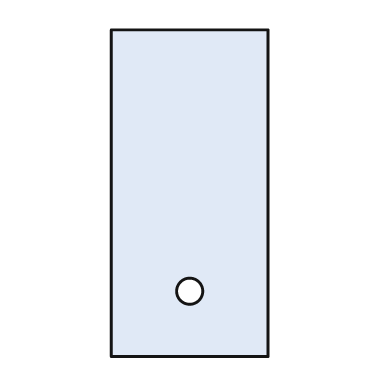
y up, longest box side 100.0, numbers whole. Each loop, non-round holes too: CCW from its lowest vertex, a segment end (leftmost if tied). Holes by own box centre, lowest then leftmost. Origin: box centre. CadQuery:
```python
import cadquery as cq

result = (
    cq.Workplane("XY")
    .moveTo(-24.0, -50.0)
    .lineTo(24.0, -50.0)
    .lineTo(24.0, 50.0)
    .lineTo(-24.0, 50.0)
    .close()
    .moveTo(0.0, -30.0)
    .circle(4.0)
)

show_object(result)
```